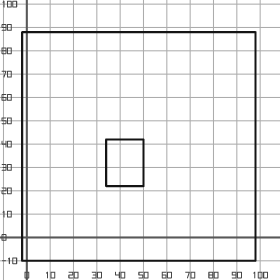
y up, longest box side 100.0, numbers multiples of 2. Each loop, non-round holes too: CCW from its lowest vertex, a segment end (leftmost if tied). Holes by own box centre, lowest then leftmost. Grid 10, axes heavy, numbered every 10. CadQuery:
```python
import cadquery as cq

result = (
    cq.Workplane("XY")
    .moveTo(-2.0, -10.0)
    .lineTo(98.0, -10.0)
    .lineTo(98.0, 88.0)
    .lineTo(-2.0, 88.0)
    .close()
    .moveTo(34.0, 22.0)
    .lineTo(50.0, 22.0)
    .lineTo(50.0, 42.0)
    .lineTo(34.0, 42.0)
    .close()
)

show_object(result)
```